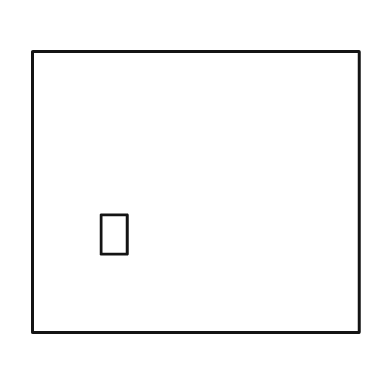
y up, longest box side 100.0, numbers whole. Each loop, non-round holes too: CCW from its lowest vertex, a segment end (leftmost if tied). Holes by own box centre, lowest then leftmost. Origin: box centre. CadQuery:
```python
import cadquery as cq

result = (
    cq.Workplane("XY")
    .moveTo(-50.0, -43.0)
    .lineTo(50.0, -43.0)
    .lineTo(50.0, 43.0)
    .lineTo(-50.0, 43.0)
    .close()
    .moveTo(-29.0, -19.0)
    .lineTo(-21.0, -19.0)
    .lineTo(-21.0, -7.0)
    .lineTo(-29.0, -7.0)
    .close()
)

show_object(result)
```